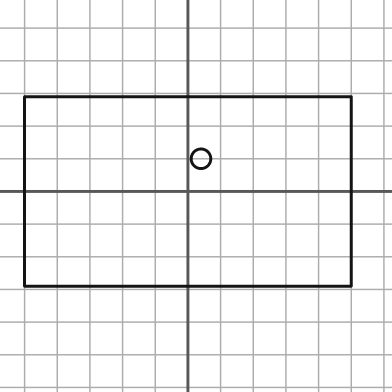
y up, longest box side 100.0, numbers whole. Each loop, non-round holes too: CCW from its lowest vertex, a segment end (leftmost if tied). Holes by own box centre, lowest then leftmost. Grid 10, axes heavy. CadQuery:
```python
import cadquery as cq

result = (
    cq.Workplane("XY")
    .moveTo(-50.0, -29.0)
    .lineTo(50.0, -29.0)
    .lineTo(50.0, 29.0)
    .lineTo(-50.0, 29.0)
    .close()
    .moveTo(4.0, 10.0)
    .circle(3.0)
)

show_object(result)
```